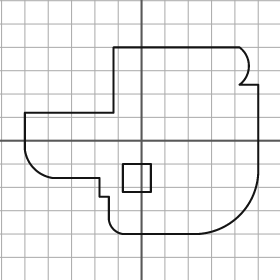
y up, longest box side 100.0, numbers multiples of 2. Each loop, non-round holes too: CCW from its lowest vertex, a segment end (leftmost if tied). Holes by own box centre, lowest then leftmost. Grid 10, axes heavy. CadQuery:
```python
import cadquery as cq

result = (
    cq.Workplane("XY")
    .moveTo(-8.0, -40.0)
    .lineTo(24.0, -40.0)
    .threePointArc((42.0, -32.0), (50.0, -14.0))
    .lineTo(50.0, 24.0)
    .lineTo(42.0, 24.0)
    .threePointArc((46.0, 32.0), (42.0, 40.0))
    .lineTo(-12.0, 40.0)
    .lineTo(-12.0, 12.0)
    .lineTo(-50.0, 12.0)
    .lineTo(-50.0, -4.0)
    .threePointArc((-46.0, -12.0), (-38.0, -16.0))
    .lineTo(-18.0, -16.0)
    .lineTo(-18.0, -24.0)
    .lineTo(-14.0, -24.0)
    .lineTo(-14.0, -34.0)
    .threePointArc((-12.0, -38.0), (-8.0, -40.0))
    .close()
    .moveTo(-8.0, -22.0)
    .lineTo(4.0, -22.0)
    .lineTo(4.0, -10.0)
    .lineTo(-8.0, -10.0)
    .close()
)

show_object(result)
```